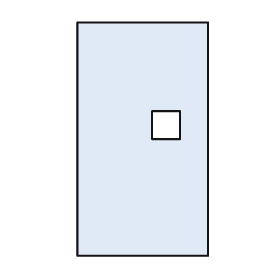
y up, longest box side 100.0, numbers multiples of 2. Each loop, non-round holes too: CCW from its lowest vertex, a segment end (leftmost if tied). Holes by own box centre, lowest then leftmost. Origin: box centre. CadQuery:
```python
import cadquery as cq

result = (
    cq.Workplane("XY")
    .moveTo(-28.0, -50.0)
    .lineTo(28.0, -50.0)
    .lineTo(28.0, 50.0)
    .lineTo(-28.0, 50.0)
    .close()
    .moveTo(4.0, 0.0)
    .lineTo(16.0, 0.0)
    .lineTo(16.0, 12.0)
    .lineTo(4.0, 12.0)
    .close()
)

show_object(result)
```